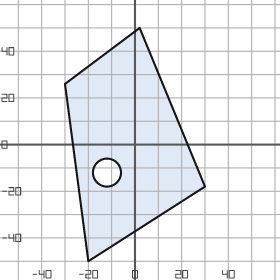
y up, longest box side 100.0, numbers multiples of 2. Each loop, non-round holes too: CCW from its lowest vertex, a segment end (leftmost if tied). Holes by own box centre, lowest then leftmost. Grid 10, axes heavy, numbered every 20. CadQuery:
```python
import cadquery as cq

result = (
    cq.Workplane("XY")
    .moveTo(-20.0, -50.0)
    .lineTo(30.0, -18.0)
    .lineTo(2.0, 50.0)
    .lineTo(-30.0, 26.0)
    .close()
    .moveTo(-12.0, -12.0)
    .circle(6.0)
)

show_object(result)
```